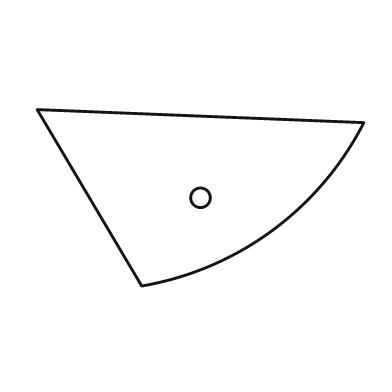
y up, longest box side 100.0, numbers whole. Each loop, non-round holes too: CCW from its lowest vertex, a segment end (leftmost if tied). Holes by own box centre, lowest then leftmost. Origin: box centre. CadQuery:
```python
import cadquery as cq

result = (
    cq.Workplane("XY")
    .moveTo(-18.0, -27.0)
    .threePointArc((22.0, -10.0), (50.0, 23.0))
    .lineTo(-50.0, 27.0)
    .close()
    .moveTo(0.0, 0.0)
    .circle(3.0)
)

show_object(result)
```